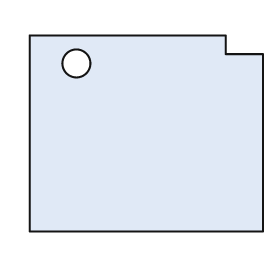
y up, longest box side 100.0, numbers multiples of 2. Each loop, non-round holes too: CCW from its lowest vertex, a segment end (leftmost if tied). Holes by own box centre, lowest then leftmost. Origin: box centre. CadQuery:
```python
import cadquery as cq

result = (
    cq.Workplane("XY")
    .moveTo(-50.0, -42.0)
    .lineTo(50.0, -42.0)
    .lineTo(50.0, 34.0)
    .lineTo(34.0, 34.0)
    .lineTo(34.0, 42.0)
    .lineTo(-50.0, 42.0)
    .close()
    .moveTo(-30.0, 30.0)
    .circle(6.0)
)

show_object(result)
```